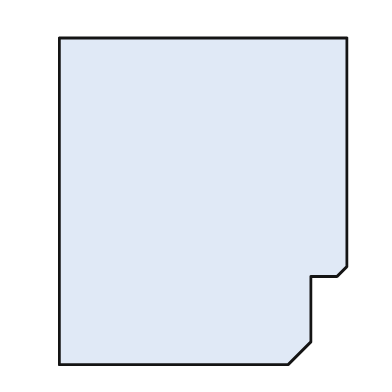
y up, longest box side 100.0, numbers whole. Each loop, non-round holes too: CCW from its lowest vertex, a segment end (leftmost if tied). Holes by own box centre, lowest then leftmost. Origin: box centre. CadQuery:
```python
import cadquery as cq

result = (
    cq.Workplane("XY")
    .moveTo(-44.0, -50.0)
    .lineTo(26.0, -50.0)
    .lineTo(33.0, -43.0)
    .lineTo(33.0, -23.0)
    .lineTo(41.0, -23.0)
    .lineTo(44.0, -20.0)
    .lineTo(44.0, 50.0)
    .lineTo(-44.0, 50.0)
    .close()
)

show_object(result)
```